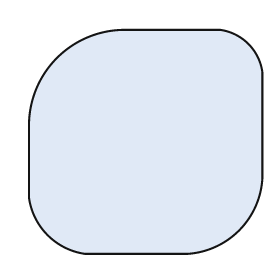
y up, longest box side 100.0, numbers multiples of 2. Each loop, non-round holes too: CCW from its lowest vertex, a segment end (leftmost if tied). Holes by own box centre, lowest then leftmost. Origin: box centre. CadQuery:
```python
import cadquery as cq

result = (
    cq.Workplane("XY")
    .moveTo(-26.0, -48.0)
    .lineTo(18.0, -48.0)
    .threePointArc((40.0, -38.0), (50.0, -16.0))
    .lineTo(50.0, 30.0)
    .threePointArc((44.0, 42.0), (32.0, 48.0))
    .lineTo(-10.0, 48.0)
    .threePointArc((-38.0, 36.0), (-50.0, 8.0))
    .lineTo(-50.0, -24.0)
    .threePointArc((-42.0, -40.0), (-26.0, -48.0))
    .close()
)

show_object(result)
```